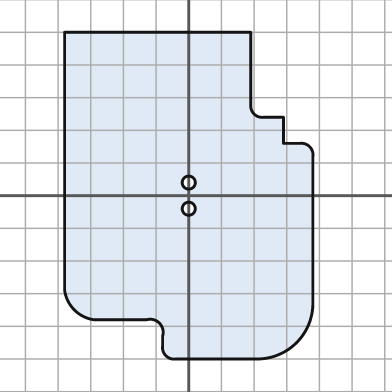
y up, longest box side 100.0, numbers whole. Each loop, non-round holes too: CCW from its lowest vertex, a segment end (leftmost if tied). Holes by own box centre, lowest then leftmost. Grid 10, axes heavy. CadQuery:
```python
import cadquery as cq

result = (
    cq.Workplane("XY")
    .moveTo(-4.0, -50.0)
    .lineTo(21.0, -50.0)
    .threePointArc((33.0, -45.0), (38.0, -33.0))
    .lineTo(38.0, 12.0)
    .threePointArc((37.0, 15.0), (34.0, 16.0))
    .lineTo(29.0, 16.0)
    .lineTo(29.0, 24.0)
    .lineTo(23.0, 24.0)
    .threePointArc((20.0, 25.0), (19.0, 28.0))
    .lineTo(19.0, 50.0)
    .lineTo(-38.0, 50.0)
    .lineTo(-38.0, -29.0)
    .threePointArc((-35.0, -35.0), (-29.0, -38.0))
    .lineTo(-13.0, -38.0)
    .threePointArc((-9.0, -39.0), (-8.0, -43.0))
    .lineTo(-8.0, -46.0)
    .threePointArc((-7.0, -49.0), (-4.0, -50.0))
    .close()
    .moveTo(0.0, -4.0)
    .circle(2.0)
    .moveTo(0.0, 4.0)
    .circle(2.0)
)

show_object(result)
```